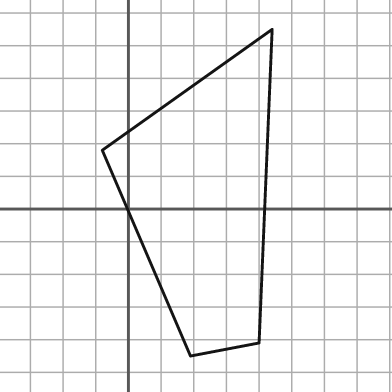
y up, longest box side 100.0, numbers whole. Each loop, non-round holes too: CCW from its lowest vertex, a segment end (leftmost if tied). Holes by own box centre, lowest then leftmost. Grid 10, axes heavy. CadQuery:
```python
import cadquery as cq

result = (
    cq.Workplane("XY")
    .moveTo(19.0, -45.0)
    .lineTo(40.0, -41.0)
    .lineTo(44.0, 55.0)
    .lineTo(-8.0, 18.0)
    .close()
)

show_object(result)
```